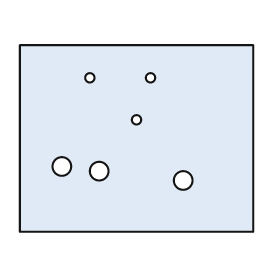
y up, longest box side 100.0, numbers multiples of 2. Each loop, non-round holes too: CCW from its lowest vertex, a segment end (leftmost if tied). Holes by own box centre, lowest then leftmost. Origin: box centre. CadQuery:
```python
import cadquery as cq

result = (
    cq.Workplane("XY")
    .moveTo(-50.0, -40.0)
    .lineTo(50.0, -40.0)
    .lineTo(50.0, 40.0)
    .lineTo(-50.0, 40.0)
    .close()
    .moveTo(20.0, -18.0)
    .circle(4.0)
    .moveTo(-16.0, -14.0)
    .circle(4.0)
    .moveTo(-32.0, -12.0)
    .circle(4.0)
    .moveTo(0.0, 8.0)
    .circle(2.0)
    .moveTo(-20.0, 26.0)
    .circle(2.0)
    .moveTo(6.0, 26.0)
    .circle(2.0)
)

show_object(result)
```